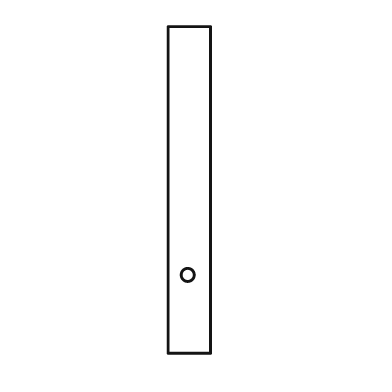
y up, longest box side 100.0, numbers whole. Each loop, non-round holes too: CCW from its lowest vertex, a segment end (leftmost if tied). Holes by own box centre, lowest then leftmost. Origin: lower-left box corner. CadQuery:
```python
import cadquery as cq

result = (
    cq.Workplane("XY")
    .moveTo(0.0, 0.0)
    .lineTo(13.0, 0.0)
    .lineTo(13.0, 100.0)
    .lineTo(0.0, 100.0)
    .close()
    .moveTo(6.0, 24.0)
    .circle(2.0)
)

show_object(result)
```